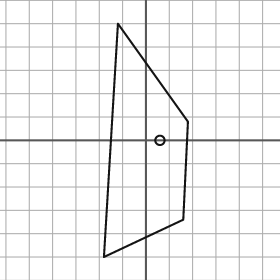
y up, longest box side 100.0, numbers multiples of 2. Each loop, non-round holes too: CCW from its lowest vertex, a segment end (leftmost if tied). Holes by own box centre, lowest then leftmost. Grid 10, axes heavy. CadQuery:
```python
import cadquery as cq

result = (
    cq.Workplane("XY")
    .moveTo(-18.0, -50.0)
    .lineTo(16.0, -34.0)
    .lineTo(18.0, 8.0)
    .lineTo(-12.0, 50.0)
    .close()
    .moveTo(6.0, 0.0)
    .circle(2.0)
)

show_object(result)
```